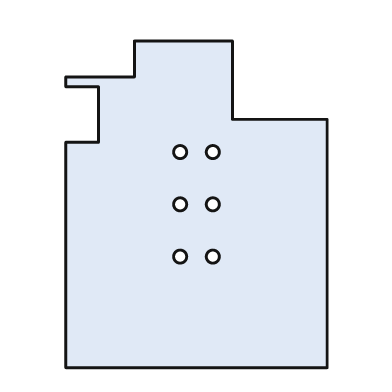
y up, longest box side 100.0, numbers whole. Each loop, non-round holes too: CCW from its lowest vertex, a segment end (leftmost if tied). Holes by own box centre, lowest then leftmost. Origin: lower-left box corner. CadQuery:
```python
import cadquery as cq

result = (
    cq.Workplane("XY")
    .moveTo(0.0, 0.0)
    .lineTo(80.0, 0.0)
    .lineTo(80.0, 76.0)
    .lineTo(51.0, 76.0)
    .lineTo(51.0, 100.0)
    .lineTo(21.0, 100.0)
    .lineTo(21.0, 89.0)
    .lineTo(0.0, 89.0)
    .lineTo(0.0, 86.0)
    .lineTo(10.0, 86.0)
    .lineTo(10.0, 69.0)
    .lineTo(0.0, 69.0)
    .close()
    .moveTo(35.0, 34.0)
    .circle(2.0)
    .moveTo(45.0, 34.0)
    .circle(2.0)
    .moveTo(35.0, 50.0)
    .circle(2.0)
    .moveTo(45.0, 50.0)
    .circle(2.0)
    .moveTo(35.0, 66.0)
    .circle(2.0)
    .moveTo(45.0, 66.0)
    .circle(2.0)
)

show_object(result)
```